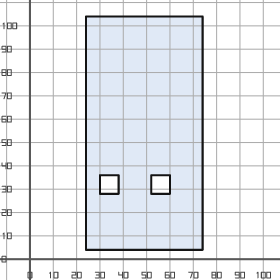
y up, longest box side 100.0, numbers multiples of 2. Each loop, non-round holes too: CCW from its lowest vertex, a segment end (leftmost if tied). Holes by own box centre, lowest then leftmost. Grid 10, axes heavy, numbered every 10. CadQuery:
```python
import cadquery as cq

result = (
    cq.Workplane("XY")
    .moveTo(24.0, 4.0)
    .lineTo(74.0, 4.0)
    .lineTo(74.0, 104.0)
    .lineTo(24.0, 104.0)
    .close()
    .moveTo(30.0, 28.0)
    .lineTo(38.0, 28.0)
    .lineTo(38.0, 36.0)
    .lineTo(30.0, 36.0)
    .close()
    .moveTo(52.0, 28.0)
    .lineTo(60.0, 28.0)
    .lineTo(60.0, 36.0)
    .lineTo(52.0, 36.0)
    .close()
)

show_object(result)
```